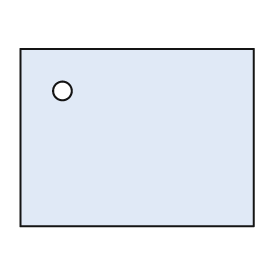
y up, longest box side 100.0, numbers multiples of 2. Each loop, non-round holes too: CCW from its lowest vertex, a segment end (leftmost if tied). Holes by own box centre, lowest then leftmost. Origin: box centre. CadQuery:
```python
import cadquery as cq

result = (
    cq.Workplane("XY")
    .moveTo(-50.0, -38.0)
    .lineTo(50.0, -38.0)
    .lineTo(50.0, 38.0)
    .lineTo(-50.0, 38.0)
    .close()
    .moveTo(-32.0, 20.0)
    .circle(4.0)
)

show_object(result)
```